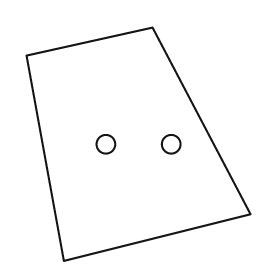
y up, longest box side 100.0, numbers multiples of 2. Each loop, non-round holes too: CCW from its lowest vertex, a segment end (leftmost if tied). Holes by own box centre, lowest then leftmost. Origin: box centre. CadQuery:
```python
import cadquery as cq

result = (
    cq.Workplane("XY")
    .moveTo(-32.0, -50.0)
    .lineTo(48.0, -30.0)
    .lineTo(6.0, 50.0)
    .lineTo(-48.0, 38.0)
    .close()
    .moveTo(-14.0, 0.0)
    .circle(4.0)
    .moveTo(14.0, 0.0)
    .circle(4.0)
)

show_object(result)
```